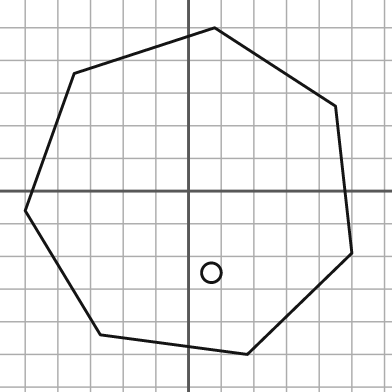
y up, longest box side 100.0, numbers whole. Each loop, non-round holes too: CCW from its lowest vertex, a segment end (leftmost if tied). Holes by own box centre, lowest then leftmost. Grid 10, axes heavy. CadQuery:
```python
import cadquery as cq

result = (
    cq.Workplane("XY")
    .moveTo(18.0, -50.0)
    .lineTo(50.0, -19.0)
    .lineTo(45.0, 26.0)
    .lineTo(8.0, 50.0)
    .lineTo(-35.0, 36.0)
    .lineTo(-50.0, -6.0)
    .lineTo(-27.0, -44.0)
    .close()
    .moveTo(7.0, -25.0)
    .circle(3.0)
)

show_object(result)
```